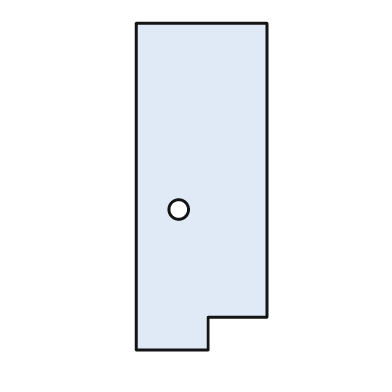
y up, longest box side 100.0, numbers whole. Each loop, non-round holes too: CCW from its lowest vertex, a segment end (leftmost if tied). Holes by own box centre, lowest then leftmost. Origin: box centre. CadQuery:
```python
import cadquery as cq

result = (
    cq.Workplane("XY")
    .moveTo(-20.0, -50.0)
    .lineTo(2.0, -50.0)
    .lineTo(2.0, -40.0)
    .lineTo(20.0, -40.0)
    .lineTo(20.0, 50.0)
    .lineTo(-20.0, 50.0)
    .close()
    .moveTo(-7.0, -7.0)
    .circle(3.0)
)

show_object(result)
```